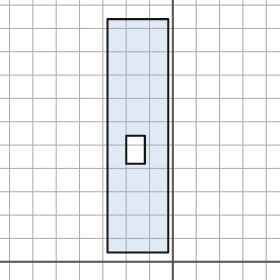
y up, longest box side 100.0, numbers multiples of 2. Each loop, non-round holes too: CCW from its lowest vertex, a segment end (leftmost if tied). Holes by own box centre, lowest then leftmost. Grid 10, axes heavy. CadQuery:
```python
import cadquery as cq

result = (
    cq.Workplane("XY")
    .moveTo(-28.0, 4.0)
    .lineTo(-2.0, 4.0)
    .lineTo(-2.0, 104.0)
    .lineTo(-28.0, 104.0)
    .close()
    .moveTo(-20.0, 42.0)
    .lineTo(-12.0, 42.0)
    .lineTo(-12.0, 54.0)
    .lineTo(-20.0, 54.0)
    .close()
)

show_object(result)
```